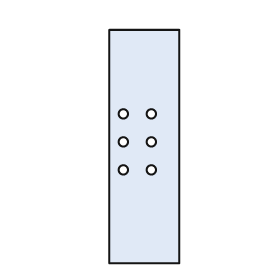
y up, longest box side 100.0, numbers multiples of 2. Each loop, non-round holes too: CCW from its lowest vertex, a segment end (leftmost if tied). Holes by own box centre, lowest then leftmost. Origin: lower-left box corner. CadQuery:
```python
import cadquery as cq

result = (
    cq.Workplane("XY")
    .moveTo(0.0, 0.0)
    .lineTo(30.0, 0.0)
    .lineTo(30.0, 100.0)
    .lineTo(0.0, 100.0)
    .close()
    .moveTo(6.0, 40.0)
    .circle(2.0)
    .moveTo(18.0, 40.0)
    .circle(2.0)
    .moveTo(6.0, 52.0)
    .circle(2.0)
    .moveTo(18.0, 52.0)
    .circle(2.0)
    .moveTo(6.0, 64.0)
    .circle(2.0)
    .moveTo(18.0, 64.0)
    .circle(2.0)
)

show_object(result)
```